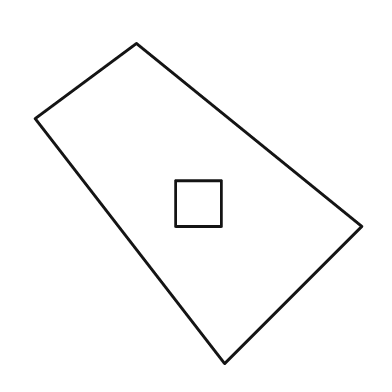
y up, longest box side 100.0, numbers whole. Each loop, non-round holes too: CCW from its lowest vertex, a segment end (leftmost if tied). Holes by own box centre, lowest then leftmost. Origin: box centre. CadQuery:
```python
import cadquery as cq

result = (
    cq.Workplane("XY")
    .moveTo(8.0, -49.0)
    .lineTo(50.0, -7.0)
    .lineTo(-19.0, 49.0)
    .lineTo(-50.0, 26.0)
    .close()
    .moveTo(-7.0, -7.0)
    .lineTo(7.0, -7.0)
    .lineTo(7.0, 7.0)
    .lineTo(-7.0, 7.0)
    .close()
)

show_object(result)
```